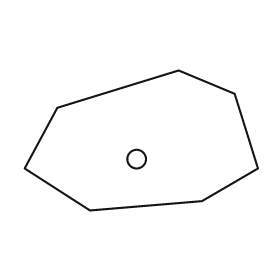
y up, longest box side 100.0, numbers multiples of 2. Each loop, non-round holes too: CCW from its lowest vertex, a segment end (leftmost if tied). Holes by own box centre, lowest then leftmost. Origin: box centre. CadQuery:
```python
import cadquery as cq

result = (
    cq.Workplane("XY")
    .moveTo(-22.0, -30.0)
    .lineTo(26.0, -26.0)
    .lineTo(50.0, -12.0)
    .lineTo(40.0, 20.0)
    .lineTo(16.0, 30.0)
    .lineTo(-36.0, 14.0)
    .lineTo(-50.0, -12.0)
    .close()
    .moveTo(-2.0, -8.0)
    .circle(4.0)
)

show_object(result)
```